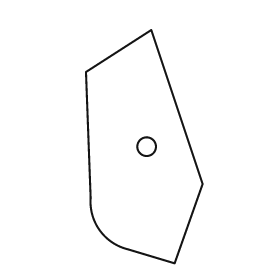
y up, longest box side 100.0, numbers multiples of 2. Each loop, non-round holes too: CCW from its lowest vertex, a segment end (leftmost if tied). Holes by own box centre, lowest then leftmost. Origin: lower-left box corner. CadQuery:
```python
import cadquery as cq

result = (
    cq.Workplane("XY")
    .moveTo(38.0, 0.0)
    .lineTo(50.0, 34.0)
    .lineTo(28.0, 100.0)
    .lineTo(0.0, 82.0)
    .lineTo(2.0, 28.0)
    .threePointArc((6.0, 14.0), (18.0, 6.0))
    .close()
    .moveTo(26.0, 50.0)
    .circle(4.0)
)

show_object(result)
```